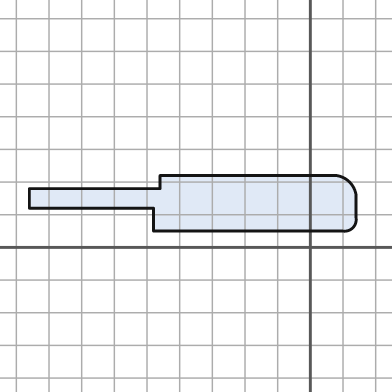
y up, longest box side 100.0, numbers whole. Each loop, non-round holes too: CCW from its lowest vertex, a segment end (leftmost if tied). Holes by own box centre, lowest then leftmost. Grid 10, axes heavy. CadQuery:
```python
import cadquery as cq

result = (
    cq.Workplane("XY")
    .moveTo(-48.0, 5.0)
    .lineTo(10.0, 5.0)
    .threePointArc((13.0, 6.0), (14.0, 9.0))
    .lineTo(14.0, 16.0)
    .threePointArc((12.0, 20.0), (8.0, 22.0))
    .lineTo(-46.0, 22.0)
    .lineTo(-46.0, 18.0)
    .lineTo(-86.0, 18.0)
    .lineTo(-86.0, 12.0)
    .lineTo(-48.0, 12.0)
    .close()
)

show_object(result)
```